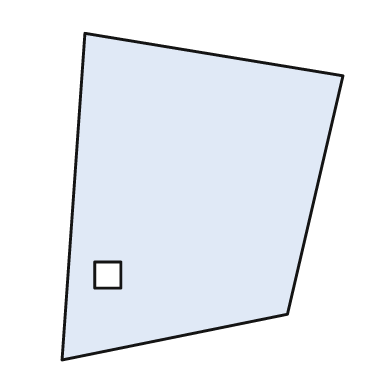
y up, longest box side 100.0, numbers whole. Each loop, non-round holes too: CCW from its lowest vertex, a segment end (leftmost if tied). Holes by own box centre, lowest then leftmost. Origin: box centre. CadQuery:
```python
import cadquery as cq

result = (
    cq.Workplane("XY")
    .moveTo(-43.0, -50.0)
    .lineTo(26.0, -36.0)
    .lineTo(43.0, 37.0)
    .lineTo(-36.0, 50.0)
    .close()
    .moveTo(-33.0, -28.0)
    .lineTo(-25.0, -28.0)
    .lineTo(-25.0, -20.0)
    .lineTo(-33.0, -20.0)
    .close()
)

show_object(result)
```